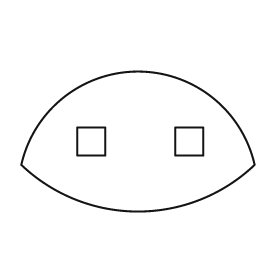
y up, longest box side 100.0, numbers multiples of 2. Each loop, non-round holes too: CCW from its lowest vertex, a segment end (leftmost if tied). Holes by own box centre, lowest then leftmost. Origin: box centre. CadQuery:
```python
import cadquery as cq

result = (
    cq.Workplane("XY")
    .moveTo(-50.0, -10.0)
    .threePointArc((0.0, -30.0), (50.0, -10.0))
    .threePointArc((0.0, 30.0), (-50.0, -10.0))
    .close()
    .moveTo(-26.0, -6.0)
    .lineTo(-14.0, -6.0)
    .lineTo(-14.0, 6.0)
    .lineTo(-26.0, 6.0)
    .close()
    .moveTo(16.0, -6.0)
    .lineTo(28.0, -6.0)
    .lineTo(28.0, 6.0)
    .lineTo(16.0, 6.0)
    .close()
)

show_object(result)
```